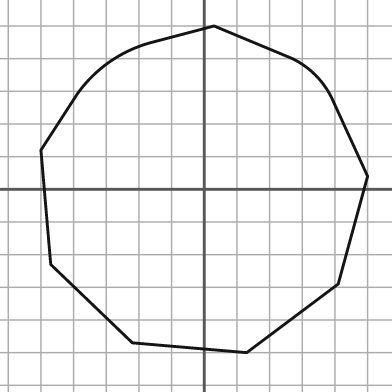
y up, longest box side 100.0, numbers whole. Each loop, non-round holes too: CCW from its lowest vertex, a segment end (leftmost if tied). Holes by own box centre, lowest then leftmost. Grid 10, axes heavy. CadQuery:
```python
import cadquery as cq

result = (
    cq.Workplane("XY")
    .moveTo(13.0, -50.0)
    .lineTo(41.0, -29.0)
    .lineTo(50.0, 4.0)
    .lineTo(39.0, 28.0)
    .threePointArc((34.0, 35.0), (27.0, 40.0))
    .lineTo(3.0, 50.0)
    .lineTo(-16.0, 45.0)
    .threePointArc((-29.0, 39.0), (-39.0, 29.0))
    .lineTo(-50.0, 12.0)
    .lineTo(-47.0, -23.0)
    .lineTo(-22.0, -47.0)
    .close()
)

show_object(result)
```